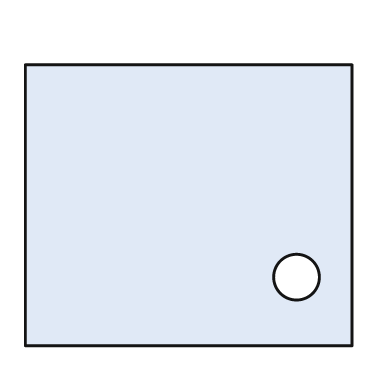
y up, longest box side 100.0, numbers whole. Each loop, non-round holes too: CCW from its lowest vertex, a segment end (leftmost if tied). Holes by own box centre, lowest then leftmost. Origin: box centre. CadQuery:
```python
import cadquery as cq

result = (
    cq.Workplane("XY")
    .moveTo(-50.0, -43.0)
    .lineTo(50.0, -43.0)
    .lineTo(50.0, 43.0)
    .lineTo(-50.0, 43.0)
    .close()
    .moveTo(33.0, -22.0)
    .circle(7.0)
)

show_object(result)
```